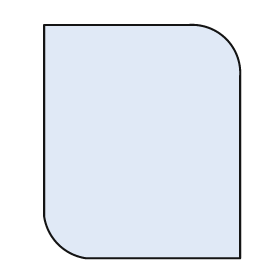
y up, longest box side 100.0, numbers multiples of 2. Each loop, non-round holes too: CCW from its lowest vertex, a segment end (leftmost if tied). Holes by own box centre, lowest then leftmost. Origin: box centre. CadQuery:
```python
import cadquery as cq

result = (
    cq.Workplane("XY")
    .moveTo(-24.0, -50.0)
    .lineTo(42.0, -50.0)
    .lineTo(42.0, 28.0)
    .threePointArc((36.0, 44.0), (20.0, 50.0))
    .lineTo(-42.0, 50.0)
    .lineTo(-42.0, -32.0)
    .threePointArc((-36.0, -44.0), (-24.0, -50.0))
    .close()
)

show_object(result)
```